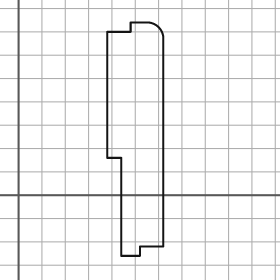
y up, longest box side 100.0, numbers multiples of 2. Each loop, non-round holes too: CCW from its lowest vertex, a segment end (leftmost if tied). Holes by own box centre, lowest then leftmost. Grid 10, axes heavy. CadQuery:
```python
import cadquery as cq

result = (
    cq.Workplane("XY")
    .moveTo(44.0, -26.0)
    .lineTo(52.0, -26.0)
    .lineTo(52.0, -22.0)
    .lineTo(62.0, -22.0)
    .lineTo(62.0, 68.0)
    .threePointArc((60.0, 72.0), (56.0, 74.0))
    .lineTo(48.0, 74.0)
    .lineTo(48.0, 70.0)
    .lineTo(38.0, 70.0)
    .lineTo(38.0, 16.0)
    .lineTo(44.0, 16.0)
    .close()
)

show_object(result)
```